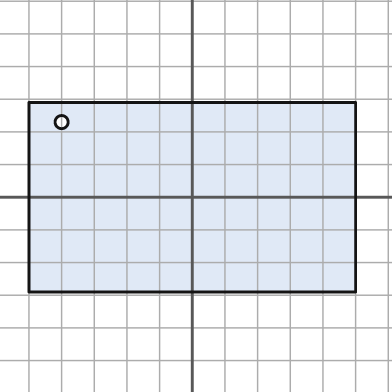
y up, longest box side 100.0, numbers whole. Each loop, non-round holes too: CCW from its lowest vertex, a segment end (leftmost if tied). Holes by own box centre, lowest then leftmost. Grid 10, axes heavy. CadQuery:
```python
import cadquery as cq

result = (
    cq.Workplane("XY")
    .moveTo(-50.0, -29.0)
    .lineTo(50.0, -29.0)
    .lineTo(50.0, 29.0)
    .lineTo(-50.0, 29.0)
    .close()
    .moveTo(-40.0, 23.0)
    .circle(2.0)
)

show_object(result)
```